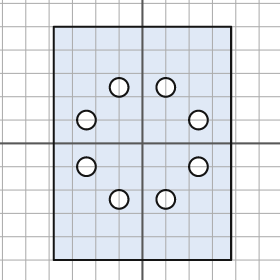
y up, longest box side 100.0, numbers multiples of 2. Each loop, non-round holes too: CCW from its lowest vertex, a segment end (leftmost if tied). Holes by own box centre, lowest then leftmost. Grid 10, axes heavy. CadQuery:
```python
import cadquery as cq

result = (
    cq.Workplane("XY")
    .moveTo(-38.0, -50.0)
    .lineTo(38.0, -50.0)
    .lineTo(38.0, 50.0)
    .lineTo(-38.0, 50.0)
    .close()
    .moveTo(-10.0, -24.0)
    .circle(4.0)
    .moveTo(10.0, -24.0)
    .circle(4.0)
    .moveTo(-24.0, -10.0)
    .circle(4.0)
    .moveTo(24.0, -10.0)
    .circle(4.0)
    .moveTo(-24.0, 10.0)
    .circle(4.0)
    .moveTo(24.0, 10.0)
    .circle(4.0)
    .moveTo(-10.0, 24.0)
    .circle(4.0)
    .moveTo(10.0, 24.0)
    .circle(4.0)
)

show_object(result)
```